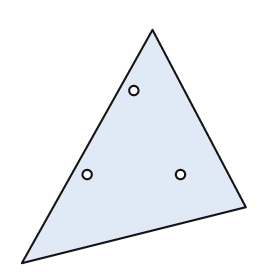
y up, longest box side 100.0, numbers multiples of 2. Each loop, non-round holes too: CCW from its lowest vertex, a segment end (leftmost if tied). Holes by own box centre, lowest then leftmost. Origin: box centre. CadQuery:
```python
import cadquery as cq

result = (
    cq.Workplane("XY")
    .moveTo(-48.0, -50.0)
    .lineTo(48.0, -26.0)
    .lineTo(8.0, 50.0)
    .close()
    .moveTo(-20.0, -12.0)
    .circle(2.0)
    .moveTo(20.0, -12.0)
    .circle(2.0)
    .moveTo(0.0, 24.0)
    .circle(2.0)
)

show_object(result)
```